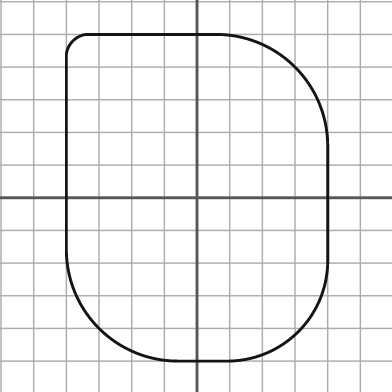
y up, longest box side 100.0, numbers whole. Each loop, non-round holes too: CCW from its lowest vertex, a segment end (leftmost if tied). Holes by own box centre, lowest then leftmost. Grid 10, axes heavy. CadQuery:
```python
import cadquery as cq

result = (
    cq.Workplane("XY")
    .moveTo(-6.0, -50.0)
    .lineTo(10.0, -50.0)
    .threePointArc((31.0, -41.0), (40.0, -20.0))
    .lineTo(40.0, 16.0)
    .threePointArc((30.0, 40.0), (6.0, 50.0))
    .lineTo(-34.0, 50.0)
    .threePointArc((-38.0, 48.0), (-40.0, 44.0))
    .lineTo(-40.0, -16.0)
    .threePointArc((-30.0, -40.0), (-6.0, -50.0))
    .close()
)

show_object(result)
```